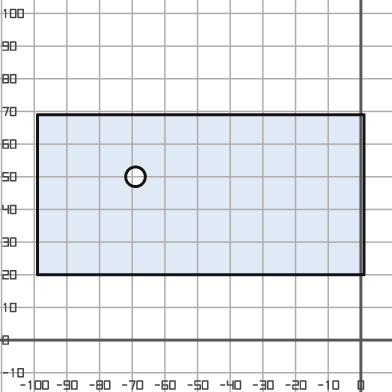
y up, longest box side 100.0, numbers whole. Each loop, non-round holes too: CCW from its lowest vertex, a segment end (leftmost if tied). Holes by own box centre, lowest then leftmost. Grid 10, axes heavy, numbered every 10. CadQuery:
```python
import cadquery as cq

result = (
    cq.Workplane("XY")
    .moveTo(-99.0, 20.0)
    .lineTo(1.0, 20.0)
    .lineTo(1.0, 69.0)
    .lineTo(-99.0, 69.0)
    .close()
    .moveTo(-69.0, 50.0)
    .circle(3.0)
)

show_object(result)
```